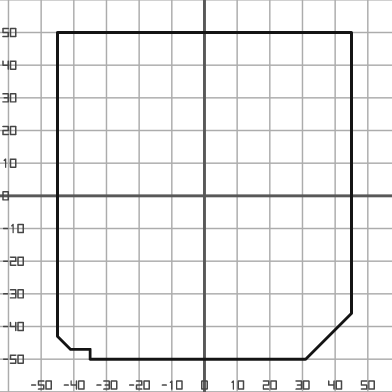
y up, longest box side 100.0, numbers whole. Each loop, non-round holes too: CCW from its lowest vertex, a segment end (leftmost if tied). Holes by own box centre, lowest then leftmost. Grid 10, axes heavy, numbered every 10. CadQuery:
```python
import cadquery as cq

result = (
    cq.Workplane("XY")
    .moveTo(-35.0, -50.0)
    .lineTo(31.0, -50.0)
    .lineTo(45.0, -36.0)
    .lineTo(45.0, 50.0)
    .lineTo(-45.0, 50.0)
    .lineTo(-45.0, -43.0)
    .lineTo(-41.0, -47.0)
    .lineTo(-35.0, -47.0)
    .close()
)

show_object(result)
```